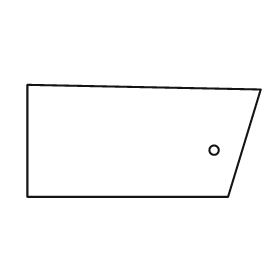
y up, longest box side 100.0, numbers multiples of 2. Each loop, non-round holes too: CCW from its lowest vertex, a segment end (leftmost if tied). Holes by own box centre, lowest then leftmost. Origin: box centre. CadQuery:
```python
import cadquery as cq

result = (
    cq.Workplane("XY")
    .moveTo(-50.0, -24.0)
    .lineTo(36.0, -24.0)
    .lineTo(50.0, 22.0)
    .lineTo(-50.0, 24.0)
    .close()
    .moveTo(30.0, -4.0)
    .circle(2.0)
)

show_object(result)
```